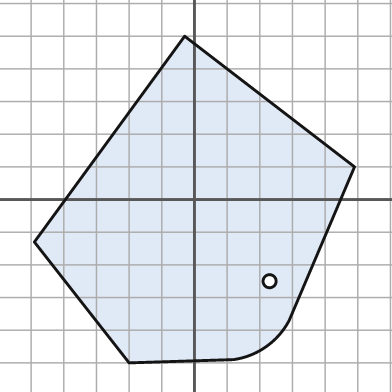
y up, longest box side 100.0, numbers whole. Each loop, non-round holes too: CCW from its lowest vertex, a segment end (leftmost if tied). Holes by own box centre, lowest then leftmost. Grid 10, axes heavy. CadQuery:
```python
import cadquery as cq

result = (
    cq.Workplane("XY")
    .moveTo(-20.0, -50.0)
    .lineTo(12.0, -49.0)
    .threePointArc((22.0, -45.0), (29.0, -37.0))
    .lineTo(49.0, 10.0)
    .lineTo(-3.0, 50.0)
    .lineTo(-49.0, -13.0)
    .close()
    .moveTo(23.0, -25.0)
    .circle(2.0)
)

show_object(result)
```